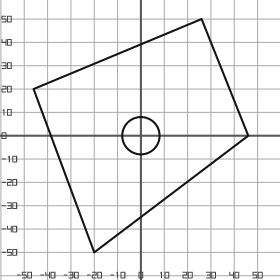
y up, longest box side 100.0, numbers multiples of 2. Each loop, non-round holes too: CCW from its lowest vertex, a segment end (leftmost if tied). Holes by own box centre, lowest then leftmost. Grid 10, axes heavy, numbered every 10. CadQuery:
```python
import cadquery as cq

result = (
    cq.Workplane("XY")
    .moveTo(-20.0, -50.0)
    .lineTo(46.0, 0.0)
    .lineTo(26.0, 50.0)
    .lineTo(-46.0, 20.0)
    .close()
    .moveTo(0.0, 0.0)
    .circle(8.0)
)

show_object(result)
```